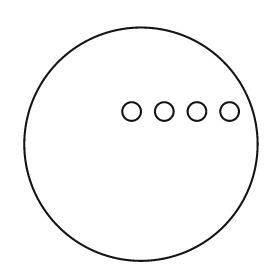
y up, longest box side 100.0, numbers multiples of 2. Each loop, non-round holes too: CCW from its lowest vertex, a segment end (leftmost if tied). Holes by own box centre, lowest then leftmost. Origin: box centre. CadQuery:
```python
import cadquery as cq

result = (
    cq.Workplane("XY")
    .moveTo(0.0, 0.0)
    .circle(50.0)
    .moveTo(-4.0, 14.0)
    .circle(4.0)
    .moveTo(10.0, 14.0)
    .circle(4.0)
    .moveTo(24.0, 14.0)
    .circle(4.0)
    .moveTo(38.0, 14.0)
    .circle(4.0)
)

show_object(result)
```